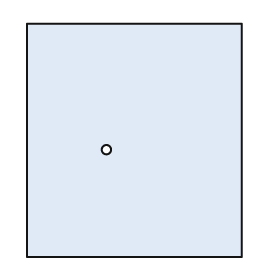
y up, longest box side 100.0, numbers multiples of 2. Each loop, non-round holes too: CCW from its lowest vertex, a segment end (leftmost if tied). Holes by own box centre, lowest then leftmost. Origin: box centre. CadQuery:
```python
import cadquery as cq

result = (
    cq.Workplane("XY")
    .moveTo(-46.0, -50.0)
    .lineTo(46.0, -50.0)
    .lineTo(46.0, 50.0)
    .lineTo(-46.0, 50.0)
    .close()
    .moveTo(-12.0, -4.0)
    .circle(2.0)
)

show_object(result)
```